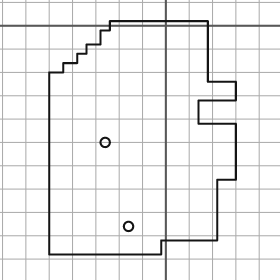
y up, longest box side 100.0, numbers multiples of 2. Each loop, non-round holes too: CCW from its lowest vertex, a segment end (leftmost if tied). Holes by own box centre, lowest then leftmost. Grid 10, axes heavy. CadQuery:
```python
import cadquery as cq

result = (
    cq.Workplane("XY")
    .moveTo(-50.0, -98.0)
    .lineTo(-2.0, -98.0)
    .lineTo(-2.0, -92.0)
    .lineTo(22.0, -92.0)
    .lineTo(22.0, -66.0)
    .lineTo(30.0, -66.0)
    .lineTo(30.0, -42.0)
    .lineTo(14.0, -42.0)
    .lineTo(14.0, -32.0)
    .lineTo(30.0, -32.0)
    .lineTo(30.0, -24.0)
    .lineTo(18.0, -24.0)
    .lineTo(18.0, 2.0)
    .lineTo(-24.0, 2.0)
    .lineTo(-24.0, -2.0)
    .lineTo(-28.0, -2.0)
    .lineTo(-28.0, -8.0)
    .lineTo(-34.0, -8.0)
    .lineTo(-34.0, -12.0)
    .lineTo(-38.0, -12.0)
    .lineTo(-38.0, -16.0)
    .lineTo(-44.0, -16.0)
    .lineTo(-44.0, -20.0)
    .lineTo(-50.0, -20.0)
    .close()
    .moveTo(-16.0, -86.0)
    .circle(2.0)
    .moveTo(-26.0, -50.0)
    .circle(2.0)
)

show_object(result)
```